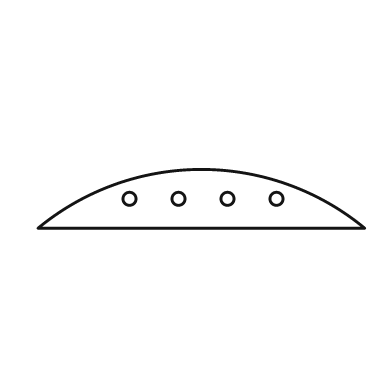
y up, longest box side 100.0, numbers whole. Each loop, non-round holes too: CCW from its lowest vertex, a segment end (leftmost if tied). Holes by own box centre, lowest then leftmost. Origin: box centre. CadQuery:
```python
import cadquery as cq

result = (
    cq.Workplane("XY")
    .moveTo(-50.0, -9.0)
    .lineTo(50.0, -9.0)
    .threePointArc((0.0, 9.0), (-50.0, -9.0))
    .close()
    .moveTo(-22.0, 0.0)
    .circle(2.0)
    .moveTo(-7.0, 0.0)
    .circle(2.0)
    .moveTo(8.0, 0.0)
    .circle(2.0)
    .moveTo(23.0, 0.0)
    .circle(2.0)
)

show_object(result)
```